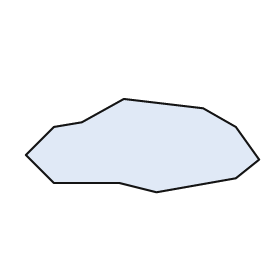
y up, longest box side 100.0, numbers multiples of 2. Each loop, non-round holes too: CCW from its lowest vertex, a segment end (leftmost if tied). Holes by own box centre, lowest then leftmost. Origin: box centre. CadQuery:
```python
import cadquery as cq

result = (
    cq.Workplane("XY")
    .moveTo(6.0, -20.0)
    .lineTo(40.0, -14.0)
    .lineTo(50.0, -6.0)
    .lineTo(40.0, 8.0)
    .lineTo(26.0, 16.0)
    .lineTo(-8.0, 20.0)
    .lineTo(-26.0, 10.0)
    .lineTo(-38.0, 8.0)
    .lineTo(-50.0, -4.0)
    .lineTo(-38.0, -16.0)
    .lineTo(-10.0, -16.0)
    .close()
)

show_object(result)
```